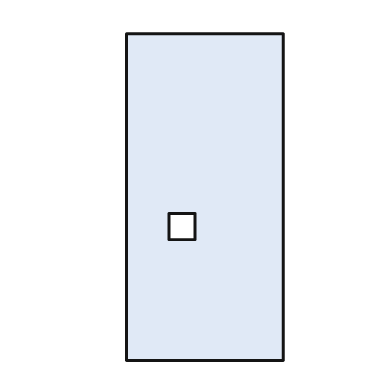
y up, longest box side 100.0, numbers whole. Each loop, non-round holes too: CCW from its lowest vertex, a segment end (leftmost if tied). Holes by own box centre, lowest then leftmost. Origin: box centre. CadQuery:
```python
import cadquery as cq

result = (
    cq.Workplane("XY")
    .moveTo(-24.0, -50.0)
    .lineTo(24.0, -50.0)
    .lineTo(24.0, 50.0)
    .lineTo(-24.0, 50.0)
    .close()
    .moveTo(-11.0, -13.0)
    .lineTo(-3.0, -13.0)
    .lineTo(-3.0, -5.0)
    .lineTo(-11.0, -5.0)
    .close()
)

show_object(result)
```